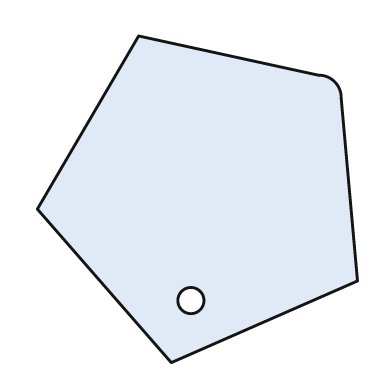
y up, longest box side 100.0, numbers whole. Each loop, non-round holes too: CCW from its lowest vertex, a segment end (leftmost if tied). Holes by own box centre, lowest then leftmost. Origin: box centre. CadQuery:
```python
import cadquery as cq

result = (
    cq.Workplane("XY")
    .moveTo(-8.0, -50.0)
    .lineTo(49.0, -25.0)
    .lineTo(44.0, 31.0)
    .threePointArc((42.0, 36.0), (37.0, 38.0))
    .lineTo(-18.0, 50.0)
    .lineTo(-49.0, -3.0)
    .close()
    .moveTo(-2.0, -31.0)
    .circle(4.0)
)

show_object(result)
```